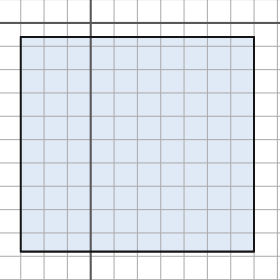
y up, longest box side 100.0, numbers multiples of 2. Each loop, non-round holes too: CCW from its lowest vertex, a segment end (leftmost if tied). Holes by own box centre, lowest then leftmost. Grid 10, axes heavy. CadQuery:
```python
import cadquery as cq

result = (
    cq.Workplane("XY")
    .moveTo(-30.0, -98.0)
    .lineTo(70.0, -98.0)
    .lineTo(70.0, -6.0)
    .lineTo(-30.0, -6.0)
    .close()
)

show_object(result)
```